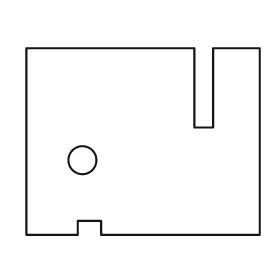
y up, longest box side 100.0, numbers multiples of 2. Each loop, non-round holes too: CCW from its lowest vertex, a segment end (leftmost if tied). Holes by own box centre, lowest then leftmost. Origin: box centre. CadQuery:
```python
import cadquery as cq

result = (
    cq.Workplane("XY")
    .moveTo(-50.0, -40.0)
    .lineTo(-28.0, -40.0)
    .lineTo(-28.0, -34.0)
    .lineTo(-18.0, -34.0)
    .lineTo(-18.0, -40.0)
    .lineTo(50.0, -40.0)
    .lineTo(50.0, 40.0)
    .lineTo(30.0, 40.0)
    .lineTo(30.0, 6.0)
    .lineTo(22.0, 6.0)
    .lineTo(22.0, 40.0)
    .lineTo(-50.0, 40.0)
    .close()
    .moveTo(-26.0, -8.0)
    .circle(6.0)
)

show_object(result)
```